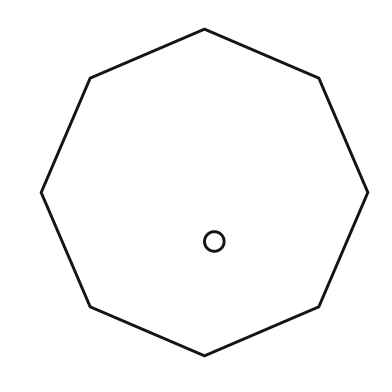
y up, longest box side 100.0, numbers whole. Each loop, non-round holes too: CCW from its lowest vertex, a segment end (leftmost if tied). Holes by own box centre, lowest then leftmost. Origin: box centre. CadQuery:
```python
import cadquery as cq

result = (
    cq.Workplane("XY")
    .moveTo(0.0, -50.0)
    .lineTo(35.0, -35.0)
    .lineTo(50.0, 0.0)
    .lineTo(35.0, 35.0)
    .lineTo(0.0, 50.0)
    .lineTo(-35.0, 35.0)
    .lineTo(-50.0, 0.0)
    .lineTo(-35.0, -35.0)
    .close()
    .moveTo(3.0, -15.0)
    .circle(3.0)
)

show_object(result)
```